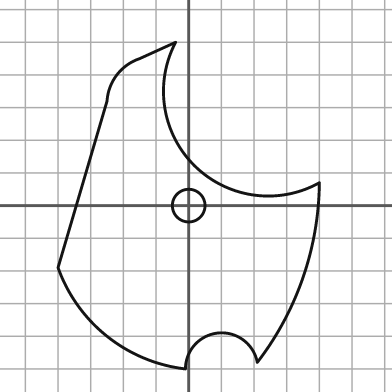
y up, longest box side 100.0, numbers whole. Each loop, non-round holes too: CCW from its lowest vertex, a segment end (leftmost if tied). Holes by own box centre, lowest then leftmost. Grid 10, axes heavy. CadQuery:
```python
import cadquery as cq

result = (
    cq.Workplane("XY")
    .moveTo(-1.0, -50.0)
    .threePointArc((9.0, -39.0), (21.0, -48.0))
    .threePointArc((35.0, -22.0), (40.0, 7.0))
    .threePointArc((2.0, 12.0), (-4.0, 50.0))
    .lineTo(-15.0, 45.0)
    .threePointArc((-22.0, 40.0), (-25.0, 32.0))
    .lineTo(-40.0, -19.0)
    .threePointArc((-25.0, -40.0), (-1.0, -50.0))
    .close()
    .moveTo(0.0, 0.0)
    .circle(5.0)
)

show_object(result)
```